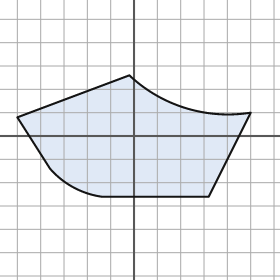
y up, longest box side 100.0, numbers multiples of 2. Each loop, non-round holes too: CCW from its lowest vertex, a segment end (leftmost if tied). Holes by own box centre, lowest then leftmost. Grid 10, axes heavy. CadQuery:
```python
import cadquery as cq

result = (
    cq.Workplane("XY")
    .moveTo(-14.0, -26.0)
    .lineTo(32.0, -26.0)
    .lineTo(50.0, 10.0)
    .threePointArc((22.0, 12.0), (-2.0, 26.0))
    .lineTo(-50.0, 8.0)
    .lineTo(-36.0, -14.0)
    .threePointArc((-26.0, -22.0), (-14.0, -26.0))
    .close()
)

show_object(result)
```